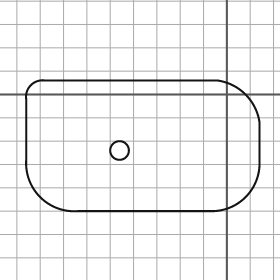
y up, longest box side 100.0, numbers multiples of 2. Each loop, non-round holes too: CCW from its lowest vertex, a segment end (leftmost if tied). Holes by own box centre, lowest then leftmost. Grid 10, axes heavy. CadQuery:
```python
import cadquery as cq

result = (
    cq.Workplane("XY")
    .moveTo(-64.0, -50.0)
    .lineTo(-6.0, -50.0)
    .threePointArc((8.0, -44.0), (14.0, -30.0))
    .lineTo(14.0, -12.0)
    .threePointArc((8.0, 0.0), (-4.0, 6.0))
    .lineTo(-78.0, 6.0)
    .threePointArc((-84.0, 4.0), (-86.0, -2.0))
    .lineTo(-86.0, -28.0)
    .threePointArc((-80.0, -44.0), (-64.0, -50.0))
    .close()
    .moveTo(-46.0, -24.0)
    .circle(4.0)
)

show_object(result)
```